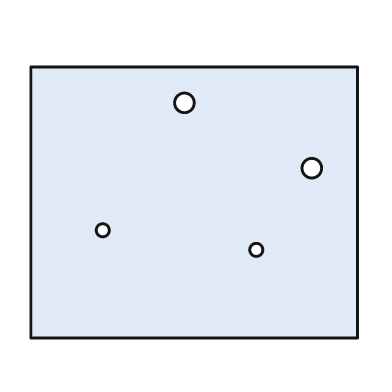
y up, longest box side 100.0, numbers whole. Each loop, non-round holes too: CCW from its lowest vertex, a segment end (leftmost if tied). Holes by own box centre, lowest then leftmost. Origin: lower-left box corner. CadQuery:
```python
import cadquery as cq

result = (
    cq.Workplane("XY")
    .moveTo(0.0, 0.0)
    .lineTo(100.0, 0.0)
    .lineTo(100.0, 83.0)
    .lineTo(0.0, 83.0)
    .close()
    .moveTo(69.0, 27.0)
    .circle(2.0)
    .moveTo(22.0, 33.0)
    .circle(2.0)
    .moveTo(86.0, 52.0)
    .circle(3.0)
    .moveTo(47.0, 72.0)
    .circle(3.0)
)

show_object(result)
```